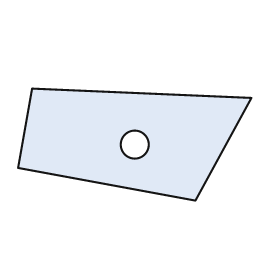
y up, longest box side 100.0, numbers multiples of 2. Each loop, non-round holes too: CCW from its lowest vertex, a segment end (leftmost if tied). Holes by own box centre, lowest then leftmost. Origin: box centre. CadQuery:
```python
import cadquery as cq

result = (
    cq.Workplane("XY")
    .moveTo(26.0, -24.0)
    .lineTo(50.0, 20.0)
    .lineTo(-44.0, 24.0)
    .lineTo(-50.0, -10.0)
    .close()
    .moveTo(0.0, 0.0)
    .circle(6.0)
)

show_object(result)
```